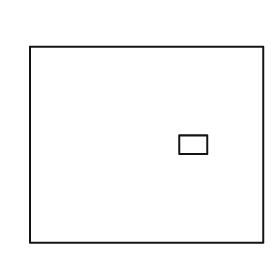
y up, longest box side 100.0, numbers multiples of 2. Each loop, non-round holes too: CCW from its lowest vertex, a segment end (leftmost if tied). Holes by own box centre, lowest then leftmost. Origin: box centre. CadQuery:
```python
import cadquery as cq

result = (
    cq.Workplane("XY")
    .moveTo(-50.0, -42.0)
    .lineTo(50.0, -42.0)
    .lineTo(50.0, 42.0)
    .lineTo(-50.0, 42.0)
    .close()
    .moveTo(14.0, -4.0)
    .lineTo(26.0, -4.0)
    .lineTo(26.0, 4.0)
    .lineTo(14.0, 4.0)
    .close()
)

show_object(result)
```